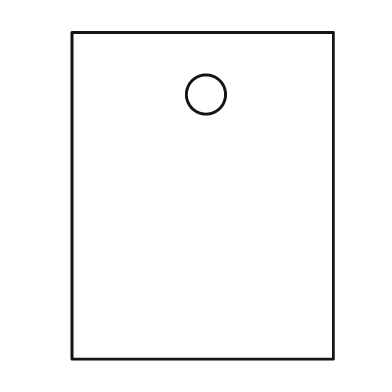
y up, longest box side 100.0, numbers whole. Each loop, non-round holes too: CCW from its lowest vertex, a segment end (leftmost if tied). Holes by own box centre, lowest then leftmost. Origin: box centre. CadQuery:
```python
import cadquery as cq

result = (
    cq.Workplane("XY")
    .moveTo(-40.0, -50.0)
    .lineTo(40.0, -50.0)
    .lineTo(40.0, 50.0)
    .lineTo(-40.0, 50.0)
    .close()
    .moveTo(1.0, 31.0)
    .circle(6.0)
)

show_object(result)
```